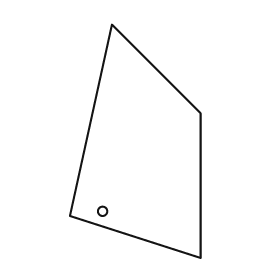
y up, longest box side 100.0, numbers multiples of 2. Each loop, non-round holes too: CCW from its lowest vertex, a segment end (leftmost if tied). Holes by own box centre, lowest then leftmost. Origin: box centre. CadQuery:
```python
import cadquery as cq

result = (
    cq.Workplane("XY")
    .moveTo(28.0, -50.0)
    .lineTo(28.0, 12.0)
    .lineTo(-10.0, 50.0)
    .lineTo(-28.0, -32.0)
    .close()
    .moveTo(-14.0, -30.0)
    .circle(2.0)
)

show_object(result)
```